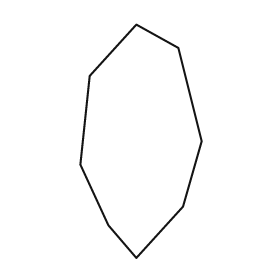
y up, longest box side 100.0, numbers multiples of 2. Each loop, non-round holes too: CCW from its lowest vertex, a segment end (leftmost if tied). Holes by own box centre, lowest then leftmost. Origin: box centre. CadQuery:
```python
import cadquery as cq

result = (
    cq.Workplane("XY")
    .moveTo(-2.0, -50.0)
    .lineTo(18.0, -28.0)
    .lineTo(26.0, 0.0)
    .lineTo(16.0, 40.0)
    .lineTo(-2.0, 50.0)
    .lineTo(-22.0, 28.0)
    .lineTo(-26.0, -10.0)
    .lineTo(-14.0, -36.0)
    .close()
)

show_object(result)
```